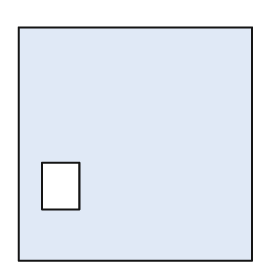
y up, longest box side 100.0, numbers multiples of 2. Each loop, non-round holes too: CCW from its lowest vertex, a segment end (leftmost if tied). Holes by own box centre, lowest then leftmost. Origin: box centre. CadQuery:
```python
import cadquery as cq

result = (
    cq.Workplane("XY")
    .moveTo(-50.0, -50.0)
    .lineTo(50.0, -50.0)
    .lineTo(50.0, 50.0)
    .lineTo(-50.0, 50.0)
    .close()
    .moveTo(-40.0, -28.0)
    .lineTo(-24.0, -28.0)
    .lineTo(-24.0, -8.0)
    .lineTo(-40.0, -8.0)
    .close()
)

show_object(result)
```